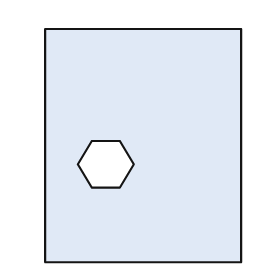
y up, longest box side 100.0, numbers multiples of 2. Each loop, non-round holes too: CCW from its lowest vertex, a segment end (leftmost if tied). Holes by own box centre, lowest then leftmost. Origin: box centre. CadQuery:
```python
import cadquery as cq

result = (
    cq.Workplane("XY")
    .moveTo(-42.0, -50.0)
    .lineTo(42.0, -50.0)
    .lineTo(42.0, 50.0)
    .lineTo(-42.0, 50.0)
    .close()
    .moveTo(-22.0, -18.0)
    .lineTo(-10.0, -18.0)
    .lineTo(-4.0, -8.0)
    .lineTo(-10.0, 2.0)
    .lineTo(-22.0, 2.0)
    .lineTo(-28.0, -8.0)
    .close()
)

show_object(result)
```